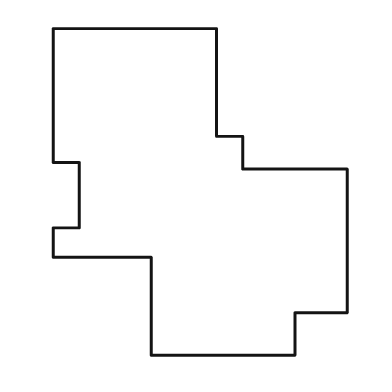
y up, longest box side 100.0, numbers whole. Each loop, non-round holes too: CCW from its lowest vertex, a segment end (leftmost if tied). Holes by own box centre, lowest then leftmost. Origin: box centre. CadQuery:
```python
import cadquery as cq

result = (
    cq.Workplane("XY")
    .moveTo(-15.0, -50.0)
    .lineTo(29.0, -50.0)
    .lineTo(29.0, -37.0)
    .lineTo(45.0, -37.0)
    .lineTo(45.0, 7.0)
    .lineTo(13.0, 7.0)
    .lineTo(13.0, 17.0)
    .lineTo(5.0, 17.0)
    .lineTo(5.0, 50.0)
    .lineTo(-45.0, 50.0)
    .lineTo(-45.0, 9.0)
    .lineTo(-37.0, 9.0)
    .lineTo(-37.0, -11.0)
    .lineTo(-45.0, -11.0)
    .lineTo(-45.0, -20.0)
    .lineTo(-15.0, -20.0)
    .close()
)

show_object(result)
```